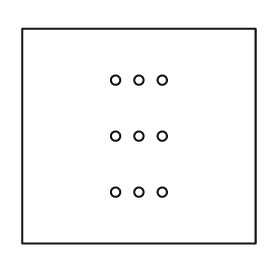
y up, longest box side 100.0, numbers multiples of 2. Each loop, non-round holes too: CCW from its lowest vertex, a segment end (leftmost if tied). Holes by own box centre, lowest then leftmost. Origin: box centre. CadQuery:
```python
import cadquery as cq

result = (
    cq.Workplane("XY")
    .moveTo(-50.0, -46.0)
    .lineTo(50.0, -46.0)
    .lineTo(50.0, 46.0)
    .lineTo(-50.0, 46.0)
    .close()
    .moveTo(-10.0, -24.0)
    .circle(2.0)
    .moveTo(0.0, -24.0)
    .circle(2.0)
    .moveTo(10.0, -24.0)
    .circle(2.0)
    .moveTo(-10.0, 0.0)
    .circle(2.0)
    .moveTo(0.0, 0.0)
    .circle(2.0)
    .moveTo(10.0, 0.0)
    .circle(2.0)
    .moveTo(-10.0, 24.0)
    .circle(2.0)
    .moveTo(0.0, 24.0)
    .circle(2.0)
    .moveTo(10.0, 24.0)
    .circle(2.0)
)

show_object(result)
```